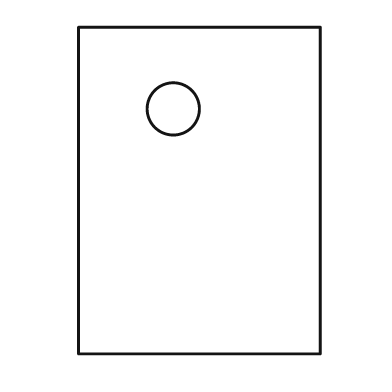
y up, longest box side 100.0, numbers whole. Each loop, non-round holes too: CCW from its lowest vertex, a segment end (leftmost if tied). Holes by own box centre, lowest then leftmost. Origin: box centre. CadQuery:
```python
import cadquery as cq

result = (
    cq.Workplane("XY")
    .moveTo(-37.0, -50.0)
    .lineTo(37.0, -50.0)
    .lineTo(37.0, 50.0)
    .lineTo(-37.0, 50.0)
    .close()
    .moveTo(-8.0, 25.0)
    .circle(8.0)
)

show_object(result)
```